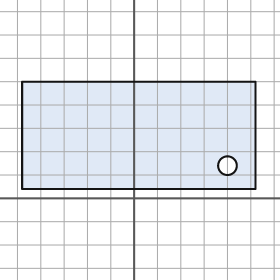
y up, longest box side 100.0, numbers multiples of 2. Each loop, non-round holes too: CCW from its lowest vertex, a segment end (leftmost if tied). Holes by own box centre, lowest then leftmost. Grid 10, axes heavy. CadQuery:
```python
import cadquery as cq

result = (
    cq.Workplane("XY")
    .moveTo(-48.0, 4.0)
    .lineTo(52.0, 4.0)
    .lineTo(52.0, 50.0)
    .lineTo(-48.0, 50.0)
    .close()
    .moveTo(40.0, 14.0)
    .circle(4.0)
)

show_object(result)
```